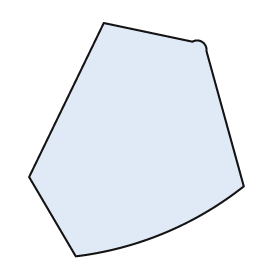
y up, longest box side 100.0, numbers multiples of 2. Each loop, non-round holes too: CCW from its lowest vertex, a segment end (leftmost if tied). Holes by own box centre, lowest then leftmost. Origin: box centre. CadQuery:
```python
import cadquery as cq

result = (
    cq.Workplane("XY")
    .moveTo(-26.0, -50.0)
    .threePointArc((12.0, -40.0), (46.0, -20.0))
    .lineTo(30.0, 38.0)
    .threePointArc((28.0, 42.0), (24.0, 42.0))
    .lineTo(-14.0, 50.0)
    .lineTo(-46.0, -16.0)
    .close()
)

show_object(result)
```